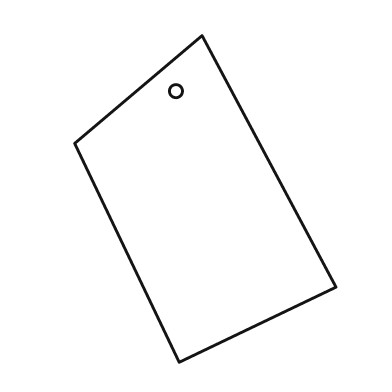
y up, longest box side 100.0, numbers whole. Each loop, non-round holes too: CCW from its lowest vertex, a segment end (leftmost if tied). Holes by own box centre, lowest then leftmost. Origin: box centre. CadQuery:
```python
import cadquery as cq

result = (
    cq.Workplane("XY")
    .moveTo(-8.0, -50.0)
    .lineTo(40.0, -27.0)
    .lineTo(-1.0, 50.0)
    .lineTo(-40.0, 17.0)
    .close()
    .moveTo(-9.0, 33.0)
    .circle(2.0)
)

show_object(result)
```